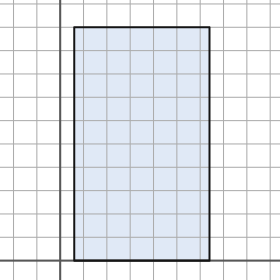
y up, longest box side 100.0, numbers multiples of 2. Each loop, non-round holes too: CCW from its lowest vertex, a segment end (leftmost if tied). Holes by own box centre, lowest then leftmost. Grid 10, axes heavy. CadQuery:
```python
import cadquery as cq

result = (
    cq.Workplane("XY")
    .moveTo(6.0, 0.0)
    .lineTo(64.0, 0.0)
    .lineTo(64.0, 100.0)
    .lineTo(6.0, 100.0)
    .close()
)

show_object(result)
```